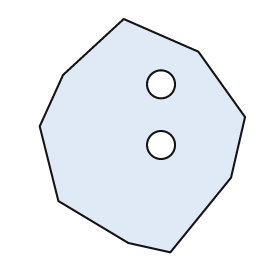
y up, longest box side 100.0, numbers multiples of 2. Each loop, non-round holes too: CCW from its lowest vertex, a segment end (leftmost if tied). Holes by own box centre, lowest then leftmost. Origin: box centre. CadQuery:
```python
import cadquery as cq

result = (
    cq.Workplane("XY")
    .moveTo(12.0, -50.0)
    .lineTo(38.0, -18.0)
    .lineTo(44.0, 8.0)
    .lineTo(24.0, 36.0)
    .lineTo(-8.0, 50.0)
    .lineTo(-34.0, 26.0)
    .lineTo(-44.0, 4.0)
    .lineTo(-36.0, -28.0)
    .lineTo(-6.0, -46.0)
    .close()
    .moveTo(8.0, -4.0)
    .circle(6.0)
    .moveTo(8.0, 22.0)
    .circle(6.0)
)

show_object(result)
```